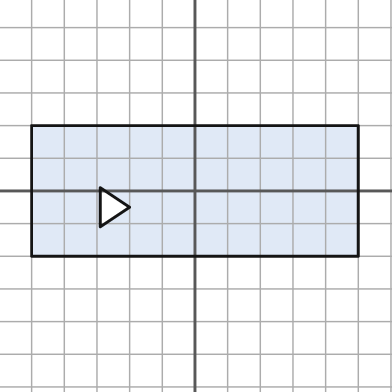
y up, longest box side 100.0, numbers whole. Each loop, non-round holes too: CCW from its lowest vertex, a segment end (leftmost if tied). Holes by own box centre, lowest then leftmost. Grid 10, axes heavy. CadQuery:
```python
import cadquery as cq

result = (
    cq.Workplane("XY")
    .moveTo(-50.0, -20.0)
    .lineTo(50.0, -20.0)
    .lineTo(50.0, 20.0)
    .lineTo(-50.0, 20.0)
    .close()
    .moveTo(-29.0, -11.0)
    .lineTo(-20.0, -5.0)
    .lineTo(-29.0, 1.0)
    .close()
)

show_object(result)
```